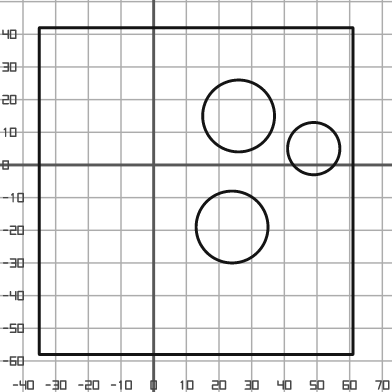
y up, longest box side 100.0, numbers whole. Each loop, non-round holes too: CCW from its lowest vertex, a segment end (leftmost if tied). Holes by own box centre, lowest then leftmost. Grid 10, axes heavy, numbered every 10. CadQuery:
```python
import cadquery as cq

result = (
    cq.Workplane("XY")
    .moveTo(-35.0, -58.0)
    .lineTo(61.0, -58.0)
    .lineTo(61.0, 42.0)
    .lineTo(-35.0, 42.0)
    .close()
    .moveTo(24.0, -19.0)
    .circle(11.0)
    .moveTo(49.0, 5.0)
    .circle(8.0)
    .moveTo(26.0, 15.0)
    .circle(11.0)
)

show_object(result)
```